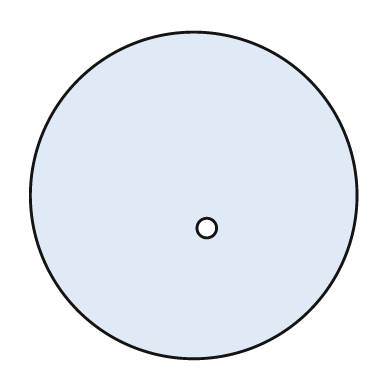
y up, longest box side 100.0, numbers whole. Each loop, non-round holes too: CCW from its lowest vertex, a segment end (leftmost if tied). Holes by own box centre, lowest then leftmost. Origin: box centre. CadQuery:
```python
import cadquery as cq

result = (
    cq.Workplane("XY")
    .moveTo(0.0, 0.0)
    .circle(50.0)
    .moveTo(4.0, -10.0)
    .circle(3.0)
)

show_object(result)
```